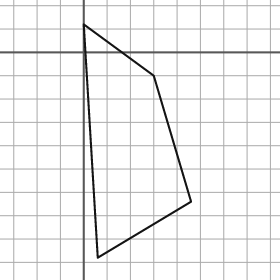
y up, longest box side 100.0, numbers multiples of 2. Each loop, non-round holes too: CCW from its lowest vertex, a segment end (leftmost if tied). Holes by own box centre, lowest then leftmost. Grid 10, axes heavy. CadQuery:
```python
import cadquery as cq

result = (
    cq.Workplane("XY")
    .moveTo(6.0, -88.0)
    .lineTo(46.0, -64.0)
    .lineTo(30.0, -10.0)
    .lineTo(0.0, 12.0)
    .close()
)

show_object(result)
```